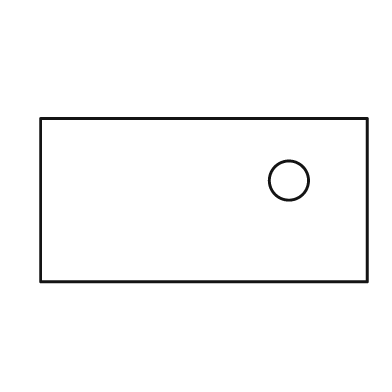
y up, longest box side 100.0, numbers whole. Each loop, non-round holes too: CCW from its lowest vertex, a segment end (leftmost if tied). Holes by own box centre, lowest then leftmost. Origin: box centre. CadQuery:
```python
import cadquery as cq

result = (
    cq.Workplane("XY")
    .moveTo(-50.0, -25.0)
    .lineTo(50.0, -25.0)
    .lineTo(50.0, 25.0)
    .lineTo(-50.0, 25.0)
    .close()
    .moveTo(26.0, 6.0)
    .circle(6.0)
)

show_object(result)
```